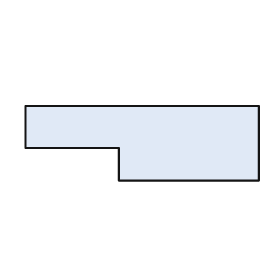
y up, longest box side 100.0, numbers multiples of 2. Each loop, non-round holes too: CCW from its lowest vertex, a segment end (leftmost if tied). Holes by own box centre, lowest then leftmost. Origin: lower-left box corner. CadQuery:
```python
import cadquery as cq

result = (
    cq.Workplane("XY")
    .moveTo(40.0, 0.0)
    .lineTo(100.0, 0.0)
    .lineTo(100.0, 32.0)
    .lineTo(0.0, 32.0)
    .lineTo(0.0, 14.0)
    .lineTo(40.0, 14.0)
    .close()
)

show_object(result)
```